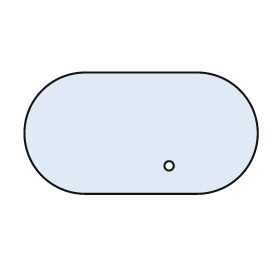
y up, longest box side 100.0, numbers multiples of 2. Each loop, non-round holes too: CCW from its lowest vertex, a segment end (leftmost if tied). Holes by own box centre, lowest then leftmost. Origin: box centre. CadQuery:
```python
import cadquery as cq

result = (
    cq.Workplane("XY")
    .moveTo(-24.0, -26.0)
    .lineTo(24.0, -26.0)
    .threePointArc((50.0, 0.0), (24.0, 26.0))
    .lineTo(-24.0, 26.0)
    .threePointArc((-50.0, 0.0), (-24.0, -26.0))
    .close()
    .moveTo(12.0, -14.0)
    .circle(2.0)
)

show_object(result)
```